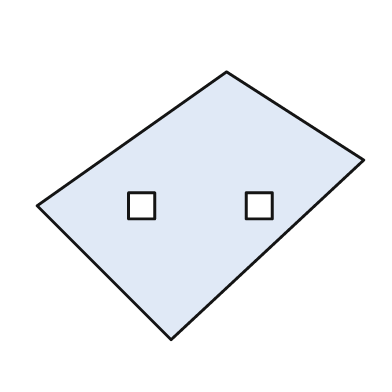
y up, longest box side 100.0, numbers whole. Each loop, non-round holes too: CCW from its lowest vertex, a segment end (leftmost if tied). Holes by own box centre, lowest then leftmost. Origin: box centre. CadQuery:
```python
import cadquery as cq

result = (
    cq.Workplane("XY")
    .moveTo(-9.0, -41.0)
    .lineTo(50.0, 14.0)
    .lineTo(8.0, 41.0)
    .lineTo(-50.0, 0.0)
    .close()
    .moveTo(-22.0, -4.0)
    .lineTo(-14.0, -4.0)
    .lineTo(-14.0, 4.0)
    .lineTo(-22.0, 4.0)
    .close()
    .moveTo(14.0, -4.0)
    .lineTo(22.0, -4.0)
    .lineTo(22.0, 4.0)
    .lineTo(14.0, 4.0)
    .close()
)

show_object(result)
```